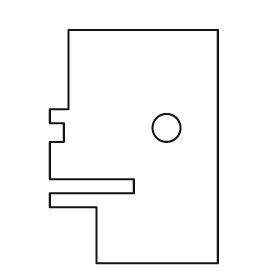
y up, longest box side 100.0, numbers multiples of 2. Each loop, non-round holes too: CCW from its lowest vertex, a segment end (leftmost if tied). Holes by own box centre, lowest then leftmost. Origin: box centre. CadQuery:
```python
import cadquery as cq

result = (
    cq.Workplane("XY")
    .moveTo(-16.0, -50.0)
    .lineTo(36.0, -50.0)
    .lineTo(36.0, 50.0)
    .lineTo(-28.0, 50.0)
    .lineTo(-28.0, 16.0)
    .lineTo(-36.0, 16.0)
    .lineTo(-36.0, 10.0)
    .lineTo(-30.0, 10.0)
    .lineTo(-30.0, 2.0)
    .lineTo(-36.0, 2.0)
    .lineTo(-36.0, -14.0)
    .lineTo(0.0, -14.0)
    .lineTo(0.0, -20.0)
    .lineTo(-36.0, -20.0)
    .lineTo(-36.0, -26.0)
    .lineTo(-16.0, -26.0)
    .close()
    .moveTo(14.0, 8.0)
    .circle(6.0)
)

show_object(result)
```